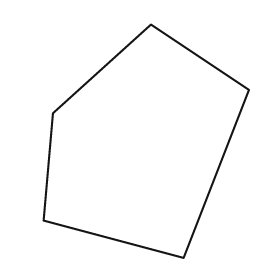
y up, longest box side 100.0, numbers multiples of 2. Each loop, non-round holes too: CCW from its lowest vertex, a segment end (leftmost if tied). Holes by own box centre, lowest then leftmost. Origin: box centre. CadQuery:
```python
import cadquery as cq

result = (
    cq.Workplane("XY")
    .moveTo(16.0, -50.0)
    .lineTo(44.0, 22.0)
    .lineTo(2.0, 50.0)
    .lineTo(-40.0, 12.0)
    .lineTo(-44.0, -34.0)
    .close()
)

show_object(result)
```